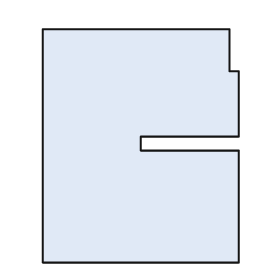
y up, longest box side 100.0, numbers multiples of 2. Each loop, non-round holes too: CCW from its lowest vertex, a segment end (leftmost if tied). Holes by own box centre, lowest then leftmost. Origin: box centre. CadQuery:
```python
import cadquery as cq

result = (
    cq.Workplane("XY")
    .moveTo(-42.0, -50.0)
    .lineTo(42.0, -50.0)
    .lineTo(42.0, -2.0)
    .lineTo(0.0, -2.0)
    .lineTo(0.0, 4.0)
    .lineTo(42.0, 4.0)
    .lineTo(42.0, 32.0)
    .lineTo(38.0, 32.0)
    .lineTo(38.0, 50.0)
    .lineTo(-42.0, 50.0)
    .close()
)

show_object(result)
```